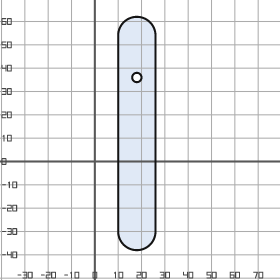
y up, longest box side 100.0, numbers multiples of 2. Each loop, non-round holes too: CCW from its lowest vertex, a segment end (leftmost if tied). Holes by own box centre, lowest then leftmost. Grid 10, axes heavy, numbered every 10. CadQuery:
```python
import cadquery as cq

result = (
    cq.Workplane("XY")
    .moveTo(10.0, -30.0)
    .threePointArc((18.0, -38.0), (26.0, -30.0))
    .lineTo(26.0, 54.0)
    .threePointArc((18.0, 62.0), (10.0, 54.0))
    .close()
    .moveTo(18.0, 36.0)
    .circle(2.0)
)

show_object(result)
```